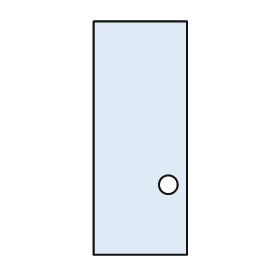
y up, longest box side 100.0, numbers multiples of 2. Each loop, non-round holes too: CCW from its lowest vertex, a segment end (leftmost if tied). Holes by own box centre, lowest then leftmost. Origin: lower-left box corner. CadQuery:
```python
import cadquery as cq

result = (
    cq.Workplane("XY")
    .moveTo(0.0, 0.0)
    .lineTo(40.0, 0.0)
    .lineTo(40.0, 100.0)
    .lineTo(0.0, 100.0)
    .close()
    .moveTo(32.0, 30.0)
    .circle(4.0)
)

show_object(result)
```